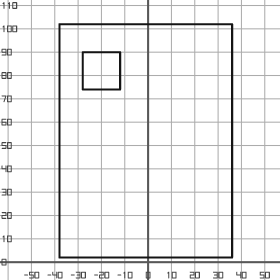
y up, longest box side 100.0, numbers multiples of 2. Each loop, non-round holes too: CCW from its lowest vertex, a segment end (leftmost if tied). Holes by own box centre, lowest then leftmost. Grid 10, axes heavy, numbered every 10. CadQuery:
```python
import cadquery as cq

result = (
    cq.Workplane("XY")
    .moveTo(-38.0, 2.0)
    .lineTo(36.0, 2.0)
    .lineTo(36.0, 102.0)
    .lineTo(-38.0, 102.0)
    .close()
    .moveTo(-28.0, 74.0)
    .lineTo(-12.0, 74.0)
    .lineTo(-12.0, 90.0)
    .lineTo(-28.0, 90.0)
    .close()
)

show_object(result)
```